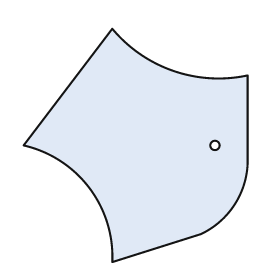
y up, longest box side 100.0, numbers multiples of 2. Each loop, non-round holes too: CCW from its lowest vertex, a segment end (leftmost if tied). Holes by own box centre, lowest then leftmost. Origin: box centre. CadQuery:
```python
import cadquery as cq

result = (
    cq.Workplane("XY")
    .moveTo(-10.0, -50.0)
    .lineTo(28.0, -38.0)
    .threePointArc((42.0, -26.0), (48.0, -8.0))
    .lineTo(48.0, 30.0)
    .threePointArc((16.0, 32.0), (-10.0, 50.0))
    .lineTo(-48.0, 0.0)
    .threePointArc((-20.0, -18.0), (-10.0, -50.0))
    .close()
    .moveTo(34.0, 0.0)
    .circle(2.0)
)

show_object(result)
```